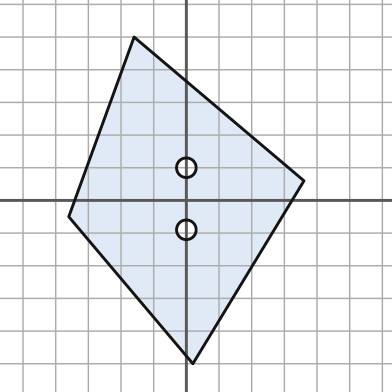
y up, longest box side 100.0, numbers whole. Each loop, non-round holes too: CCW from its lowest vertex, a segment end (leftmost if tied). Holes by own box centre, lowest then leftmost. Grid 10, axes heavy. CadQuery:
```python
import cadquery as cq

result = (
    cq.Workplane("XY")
    .moveTo(2.0, -50.0)
    .lineTo(36.0, 6.0)
    .lineTo(-16.0, 50.0)
    .lineTo(-36.0, -5.0)
    .close()
    .moveTo(0.0, -9.0)
    .circle(3.0)
    .moveTo(0.0, 10.0)
    .circle(3.0)
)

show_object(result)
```